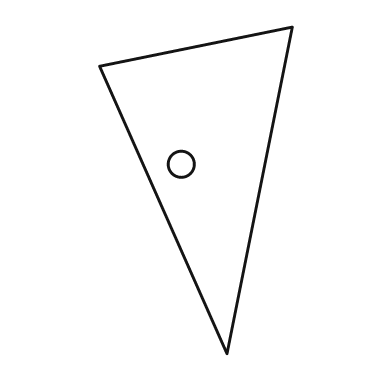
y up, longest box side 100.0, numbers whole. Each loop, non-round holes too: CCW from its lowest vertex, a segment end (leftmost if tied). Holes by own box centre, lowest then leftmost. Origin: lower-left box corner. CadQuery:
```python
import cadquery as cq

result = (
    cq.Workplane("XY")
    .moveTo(39.0, 0.0)
    .lineTo(59.0, 100.0)
    .lineTo(0.0, 88.0)
    .close()
    .moveTo(25.0, 58.0)
    .circle(4.0)
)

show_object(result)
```